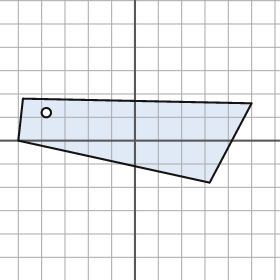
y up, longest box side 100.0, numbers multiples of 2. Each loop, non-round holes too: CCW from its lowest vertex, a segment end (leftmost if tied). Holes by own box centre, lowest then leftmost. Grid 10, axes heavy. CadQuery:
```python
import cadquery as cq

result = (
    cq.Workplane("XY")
    .moveTo(32.0, -18.0)
    .lineTo(50.0, 16.0)
    .lineTo(-48.0, 18.0)
    .lineTo(-50.0, 0.0)
    .close()
    .moveTo(-38.0, 12.0)
    .circle(2.0)
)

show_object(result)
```